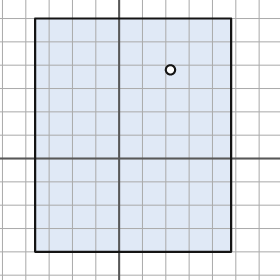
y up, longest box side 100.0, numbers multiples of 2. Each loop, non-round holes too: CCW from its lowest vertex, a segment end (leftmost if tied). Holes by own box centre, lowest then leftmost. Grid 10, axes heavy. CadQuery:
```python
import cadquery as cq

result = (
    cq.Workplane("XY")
    .moveTo(-36.0, -40.0)
    .lineTo(48.0, -40.0)
    .lineTo(48.0, 60.0)
    .lineTo(-36.0, 60.0)
    .close()
    .moveTo(22.0, 38.0)
    .circle(2.0)
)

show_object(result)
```